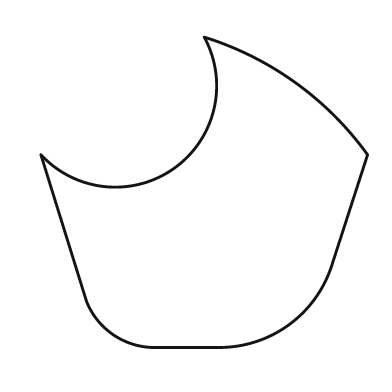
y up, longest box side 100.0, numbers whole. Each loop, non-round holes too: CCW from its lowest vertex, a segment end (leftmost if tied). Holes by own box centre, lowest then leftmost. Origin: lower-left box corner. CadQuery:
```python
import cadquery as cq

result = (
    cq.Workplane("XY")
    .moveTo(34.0, 0.0)
    .lineTo(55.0, 0.0)
    .threePointArc((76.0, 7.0), (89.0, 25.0))
    .lineTo(100.0, 59.0)
    .threePointArc((78.0, 81.0), (50.0, 95.0))
    .threePointArc((41.0, 55.0), (0.0, 59.0))
    .lineTo(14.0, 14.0)
    .threePointArc((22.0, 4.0), (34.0, 0.0))
    .close()
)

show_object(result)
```